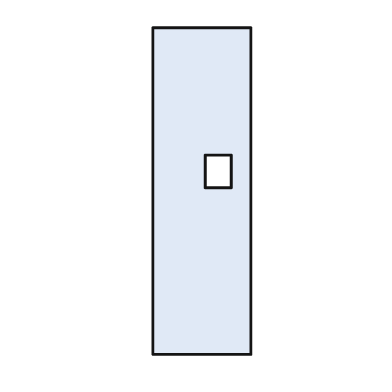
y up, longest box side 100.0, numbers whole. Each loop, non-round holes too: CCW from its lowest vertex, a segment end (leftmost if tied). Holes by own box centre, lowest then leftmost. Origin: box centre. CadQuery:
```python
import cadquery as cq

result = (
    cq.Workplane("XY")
    .moveTo(-15.0, -50.0)
    .lineTo(15.0, -50.0)
    .lineTo(15.0, 50.0)
    .lineTo(-15.0, 50.0)
    .close()
    .moveTo(1.0, 1.0)
    .lineTo(9.0, 1.0)
    .lineTo(9.0, 11.0)
    .lineTo(1.0, 11.0)
    .close()
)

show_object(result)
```